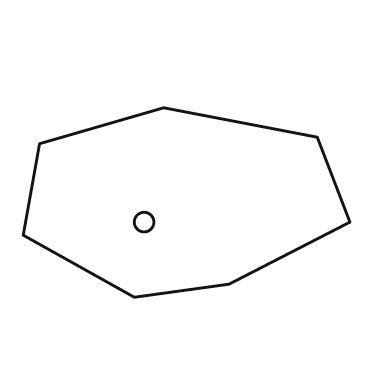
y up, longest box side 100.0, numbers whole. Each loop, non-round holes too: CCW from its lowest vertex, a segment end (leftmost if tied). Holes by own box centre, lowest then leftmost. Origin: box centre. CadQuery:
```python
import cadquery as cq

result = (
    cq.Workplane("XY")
    .moveTo(-16.0, -29.0)
    .lineTo(13.0, -25.0)
    .lineTo(50.0, -6.0)
    .lineTo(40.0, 20.0)
    .lineTo(-7.0, 29.0)
    .lineTo(-45.0, 18.0)
    .lineTo(-50.0, -10.0)
    .close()
    .moveTo(-13.0, -6.0)
    .circle(3.0)
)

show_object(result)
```